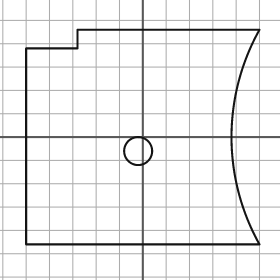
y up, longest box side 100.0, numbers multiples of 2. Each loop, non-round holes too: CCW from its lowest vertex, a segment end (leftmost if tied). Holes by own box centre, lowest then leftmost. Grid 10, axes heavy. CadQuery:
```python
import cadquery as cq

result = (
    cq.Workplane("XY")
    .moveTo(-50.0, -46.0)
    .lineTo(50.0, -46.0)
    .threePointArc((38.0, 0.0), (50.0, 46.0))
    .lineTo(-28.0, 46.0)
    .lineTo(-28.0, 38.0)
    .lineTo(-50.0, 38.0)
    .close()
    .moveTo(-2.0, -6.0)
    .circle(6.0)
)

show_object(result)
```